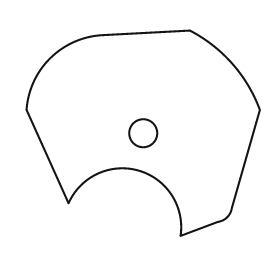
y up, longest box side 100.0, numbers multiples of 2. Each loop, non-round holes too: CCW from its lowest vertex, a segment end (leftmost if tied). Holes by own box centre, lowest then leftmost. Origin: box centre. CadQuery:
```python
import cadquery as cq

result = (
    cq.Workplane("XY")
    .moveTo(16.0, -44.0)
    .lineTo(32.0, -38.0)
    .threePointArc((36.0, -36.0), (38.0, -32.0))
    .lineTo(50.0, 10.0)
    .threePointArc((38.0, 30.0), (20.0, 44.0))
    .lineTo(-18.0, 42.0)
    .threePointArc((-40.0, 32.0), (-50.0, 10.0))
    .lineTo(-32.0, -30.0)
    .threePointArc((-2.0, -16.0), (16.0, -44.0))
    .close()
    .moveTo(0.0, 0.0)
    .circle(6.0)
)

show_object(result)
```